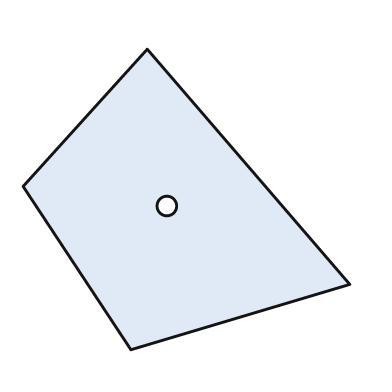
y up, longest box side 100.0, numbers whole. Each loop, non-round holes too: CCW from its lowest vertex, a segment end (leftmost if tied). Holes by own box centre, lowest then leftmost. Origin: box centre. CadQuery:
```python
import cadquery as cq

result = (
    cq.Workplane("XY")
    .moveTo(-17.0, -46.0)
    .lineTo(50.0, -26.0)
    .lineTo(-12.0, 46.0)
    .lineTo(-50.0, 4.0)
    .close()
    .moveTo(-6.0, -2.0)
    .circle(3.0)
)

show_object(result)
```